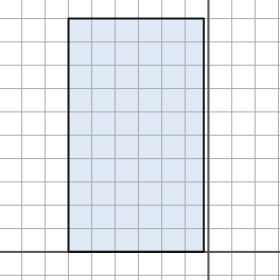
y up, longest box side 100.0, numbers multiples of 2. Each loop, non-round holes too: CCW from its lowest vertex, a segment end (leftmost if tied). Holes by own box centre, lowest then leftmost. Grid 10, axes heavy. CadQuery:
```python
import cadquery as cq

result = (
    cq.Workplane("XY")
    .moveTo(-60.0, 0.0)
    .lineTo(-2.0, 0.0)
    .lineTo(-2.0, 100.0)
    .lineTo(-60.0, 100.0)
    .close()
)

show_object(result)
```